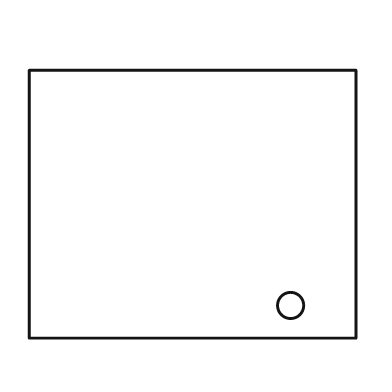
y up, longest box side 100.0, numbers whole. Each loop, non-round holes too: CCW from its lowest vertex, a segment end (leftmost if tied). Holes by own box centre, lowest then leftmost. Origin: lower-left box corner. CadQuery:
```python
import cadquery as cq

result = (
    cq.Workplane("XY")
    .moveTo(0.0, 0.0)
    .lineTo(100.0, 0.0)
    .lineTo(100.0, 82.0)
    .lineTo(0.0, 82.0)
    .close()
    .moveTo(80.0, 10.0)
    .circle(4.0)
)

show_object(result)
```